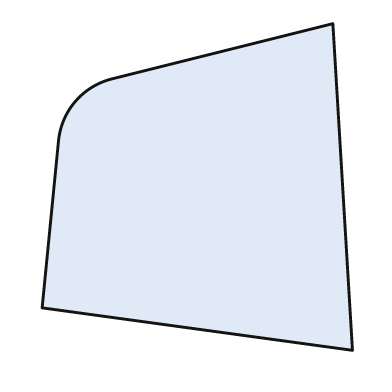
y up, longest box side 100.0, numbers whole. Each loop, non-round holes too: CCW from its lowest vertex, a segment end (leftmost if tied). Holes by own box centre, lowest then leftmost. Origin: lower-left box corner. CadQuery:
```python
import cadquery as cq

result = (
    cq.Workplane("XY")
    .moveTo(95.0, 0.0)
    .lineTo(89.0, 100.0)
    .lineTo(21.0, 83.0)
    .threePointArc((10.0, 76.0), (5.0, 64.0))
    .lineTo(0.0, 13.0)
    .close()
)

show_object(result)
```